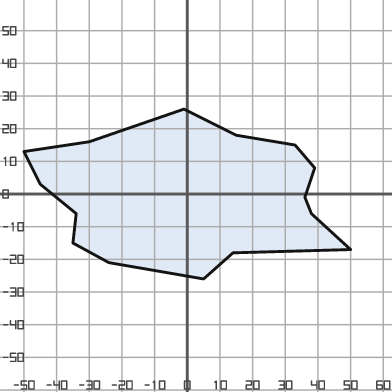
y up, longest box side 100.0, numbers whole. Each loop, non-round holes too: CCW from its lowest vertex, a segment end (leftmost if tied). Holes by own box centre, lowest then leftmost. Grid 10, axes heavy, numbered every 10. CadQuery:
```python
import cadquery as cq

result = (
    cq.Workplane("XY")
    .moveTo(5.0, -26.0)
    .lineTo(14.0, -18.0)
    .lineTo(50.0, -17.0)
    .lineTo(38.0, -6.0)
    .lineTo(36.0, -1.0)
    .lineTo(39.0, 8.0)
    .lineTo(33.0, 15.0)
    .lineTo(15.0, 18.0)
    .lineTo(-1.0, 26.0)
    .lineTo(-30.0, 16.0)
    .lineTo(-50.0, 13.0)
    .lineTo(-45.0, 3.0)
    .lineTo(-34.0, -6.0)
    .lineTo(-35.0, -15.0)
    .lineTo(-24.0, -21.0)
    .close()
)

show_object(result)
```